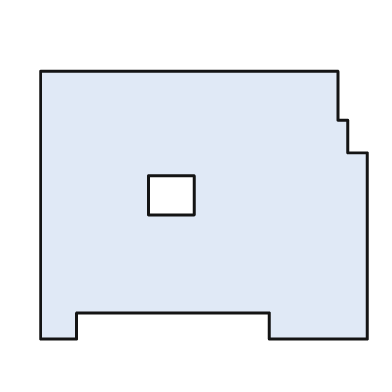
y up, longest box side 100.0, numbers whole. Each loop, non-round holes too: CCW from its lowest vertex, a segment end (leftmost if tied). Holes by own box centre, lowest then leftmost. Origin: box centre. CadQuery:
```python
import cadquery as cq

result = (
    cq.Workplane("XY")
    .moveTo(-50.0, -41.0)
    .lineTo(-39.0, -41.0)
    .lineTo(-39.0, -33.0)
    .lineTo(20.0, -33.0)
    .lineTo(20.0, -41.0)
    .lineTo(50.0, -41.0)
    .lineTo(50.0, 16.0)
    .lineTo(44.0, 16.0)
    .lineTo(44.0, 26.0)
    .lineTo(41.0, 26.0)
    .lineTo(41.0, 41.0)
    .lineTo(-50.0, 41.0)
    .close()
    .moveTo(-17.0, -3.0)
    .lineTo(-3.0, -3.0)
    .lineTo(-3.0, 9.0)
    .lineTo(-17.0, 9.0)
    .close()
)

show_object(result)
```